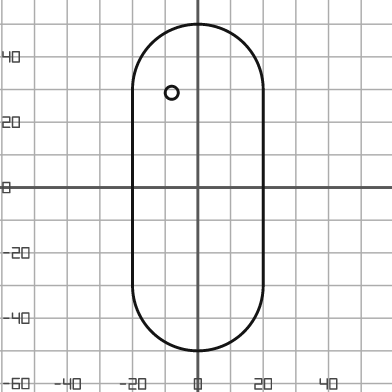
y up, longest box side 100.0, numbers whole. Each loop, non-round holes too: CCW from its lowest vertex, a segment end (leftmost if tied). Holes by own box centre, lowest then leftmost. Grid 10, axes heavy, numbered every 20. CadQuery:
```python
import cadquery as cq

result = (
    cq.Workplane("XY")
    .moveTo(-20.0, -30.0)
    .threePointArc((0.0, -50.0), (20.0, -30.0))
    .lineTo(20.0, 30.0)
    .threePointArc((0.0, 50.0), (-20.0, 30.0))
    .close()
    .moveTo(-8.0, 29.0)
    .circle(2.0)
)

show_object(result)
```